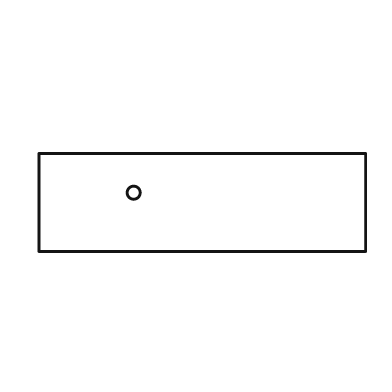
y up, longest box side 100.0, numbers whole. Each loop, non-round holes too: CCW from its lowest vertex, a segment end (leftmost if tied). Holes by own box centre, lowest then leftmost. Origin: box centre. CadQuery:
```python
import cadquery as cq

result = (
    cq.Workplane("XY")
    .moveTo(-50.0, -15.0)
    .lineTo(50.0, -15.0)
    .lineTo(50.0, 15.0)
    .lineTo(-50.0, 15.0)
    .close()
    .moveTo(-21.0, 3.0)
    .circle(2.0)
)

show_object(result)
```